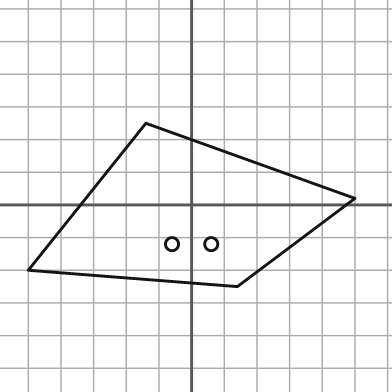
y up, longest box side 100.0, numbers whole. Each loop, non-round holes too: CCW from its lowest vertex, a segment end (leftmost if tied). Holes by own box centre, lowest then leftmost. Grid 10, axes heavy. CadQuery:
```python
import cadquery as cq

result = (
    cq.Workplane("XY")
    .moveTo(14.0, -25.0)
    .lineTo(50.0, 2.0)
    .lineTo(-14.0, 25.0)
    .lineTo(-50.0, -20.0)
    .close()
    .moveTo(-6.0, -12.0)
    .circle(2.0)
    .moveTo(6.0, -12.0)
    .circle(2.0)
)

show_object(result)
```